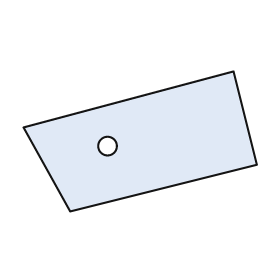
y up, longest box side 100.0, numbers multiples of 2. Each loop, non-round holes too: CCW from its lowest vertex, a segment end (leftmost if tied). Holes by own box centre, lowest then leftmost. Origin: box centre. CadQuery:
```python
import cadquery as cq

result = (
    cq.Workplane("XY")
    .moveTo(-30.0, -30.0)
    .lineTo(50.0, -10.0)
    .lineTo(40.0, 30.0)
    .lineTo(-50.0, 6.0)
    .close()
    .moveTo(-14.0, -2.0)
    .circle(4.0)
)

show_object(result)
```